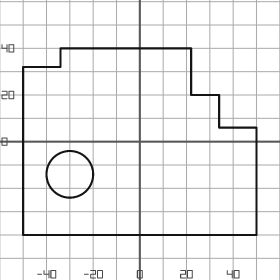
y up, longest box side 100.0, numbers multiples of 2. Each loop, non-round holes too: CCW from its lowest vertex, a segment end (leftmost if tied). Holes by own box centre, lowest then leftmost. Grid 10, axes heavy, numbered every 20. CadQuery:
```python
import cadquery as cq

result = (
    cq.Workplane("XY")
    .moveTo(-50.0, -40.0)
    .lineTo(50.0, -40.0)
    .lineTo(50.0, 6.0)
    .lineTo(34.0, 6.0)
    .lineTo(34.0, 20.0)
    .lineTo(22.0, 20.0)
    .lineTo(22.0, 40.0)
    .lineTo(-34.0, 40.0)
    .lineTo(-34.0, 32.0)
    .lineTo(-50.0, 32.0)
    .close()
    .moveTo(-30.0, -14.0)
    .circle(10.0)
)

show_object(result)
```